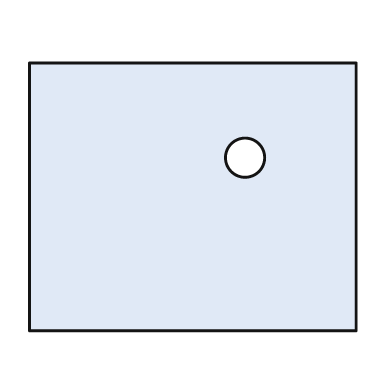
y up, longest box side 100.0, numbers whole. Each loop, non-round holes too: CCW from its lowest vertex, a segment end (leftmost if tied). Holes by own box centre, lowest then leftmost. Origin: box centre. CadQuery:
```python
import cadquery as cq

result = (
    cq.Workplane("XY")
    .moveTo(-50.0, -41.0)
    .lineTo(50.0, -41.0)
    .lineTo(50.0, 41.0)
    .lineTo(-50.0, 41.0)
    .close()
    .moveTo(16.0, 12.0)
    .circle(6.0)
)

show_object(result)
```